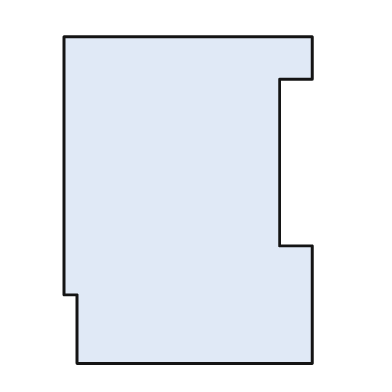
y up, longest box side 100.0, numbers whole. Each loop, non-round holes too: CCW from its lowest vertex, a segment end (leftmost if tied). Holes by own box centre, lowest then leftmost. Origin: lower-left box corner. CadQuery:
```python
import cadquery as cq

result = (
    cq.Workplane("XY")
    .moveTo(4.0, 0.0)
    .lineTo(76.0, 0.0)
    .lineTo(76.0, 36.0)
    .lineTo(66.0, 36.0)
    .lineTo(66.0, 87.0)
    .lineTo(76.0, 87.0)
    .lineTo(76.0, 100.0)
    .lineTo(0.0, 100.0)
    .lineTo(0.0, 21.0)
    .lineTo(4.0, 21.0)
    .close()
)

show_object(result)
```